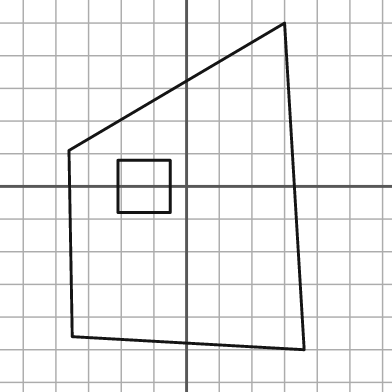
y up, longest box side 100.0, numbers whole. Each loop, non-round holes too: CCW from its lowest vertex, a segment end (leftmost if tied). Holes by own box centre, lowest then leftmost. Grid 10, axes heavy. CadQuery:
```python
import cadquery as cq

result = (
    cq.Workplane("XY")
    .moveTo(36.0, -50.0)
    .lineTo(30.0, 50.0)
    .lineTo(-36.0, 11.0)
    .lineTo(-35.0, -46.0)
    .close()
    .moveTo(-21.0, -8.0)
    .lineTo(-5.0, -8.0)
    .lineTo(-5.0, 8.0)
    .lineTo(-21.0, 8.0)
    .close()
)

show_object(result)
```